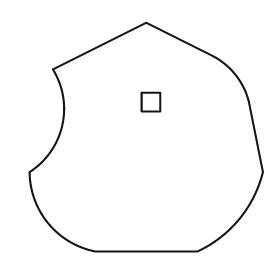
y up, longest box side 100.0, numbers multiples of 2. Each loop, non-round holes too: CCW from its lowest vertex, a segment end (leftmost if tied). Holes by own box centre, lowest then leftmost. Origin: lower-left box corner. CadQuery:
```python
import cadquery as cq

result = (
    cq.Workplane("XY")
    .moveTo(28.0, 0.0)
    .lineTo(72.0, 0.0)
    .threePointArc((90.0, 14.0), (100.0, 34.0))
    .lineTo(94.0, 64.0)
    .threePointArc((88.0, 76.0), (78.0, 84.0))
    .lineTo(50.0, 98.0)
    .lineTo(10.0, 78.0)
    .threePointArc((14.0, 54.0), (0.0, 34.0))
    .threePointArc((8.0, 12.0), (28.0, 0.0))
    .close()
    .moveTo(48.0, 60.0)
    .lineTo(56.0, 60.0)
    .lineTo(56.0, 68.0)
    .lineTo(48.0, 68.0)
    .close()
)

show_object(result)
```